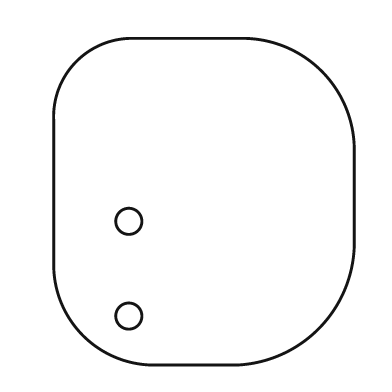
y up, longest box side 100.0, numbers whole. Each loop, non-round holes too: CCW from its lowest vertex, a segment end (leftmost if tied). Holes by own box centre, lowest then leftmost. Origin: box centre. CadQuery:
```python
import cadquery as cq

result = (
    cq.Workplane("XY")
    .moveTo(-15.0, -50.0)
    .lineTo(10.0, -50.0)
    .threePointArc((35.0, -39.0), (46.0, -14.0))
    .lineTo(46.0, 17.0)
    .threePointArc((36.0, 40.0), (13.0, 50.0))
    .lineTo(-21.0, 50.0)
    .threePointArc((-39.0, 43.0), (-46.0, 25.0))
    .lineTo(-46.0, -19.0)
    .threePointArc((-37.0, -41.0), (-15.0, -50.0))
    .close()
    .moveTo(-23.0, -35.0)
    .circle(4.0)
    .moveTo(-23.0, -6.0)
    .circle(4.0)
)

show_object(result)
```